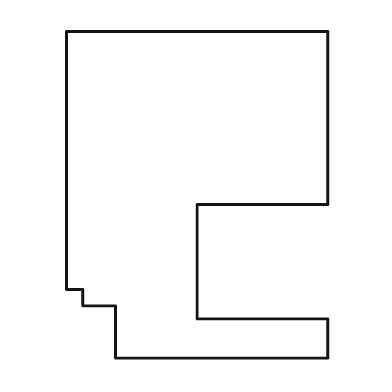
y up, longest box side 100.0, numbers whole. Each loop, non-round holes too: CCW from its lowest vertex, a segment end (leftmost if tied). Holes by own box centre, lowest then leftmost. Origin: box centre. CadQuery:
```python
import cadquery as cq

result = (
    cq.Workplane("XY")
    .moveTo(-25.0, -50.0)
    .lineTo(40.0, -50.0)
    .lineTo(40.0, -38.0)
    .lineTo(0.0, -38.0)
    .lineTo(0.0, -3.0)
    .lineTo(40.0, -3.0)
    .lineTo(40.0, 50.0)
    .lineTo(-40.0, 50.0)
    .lineTo(-40.0, -29.0)
    .lineTo(-35.0, -29.0)
    .lineTo(-35.0, -34.0)
    .lineTo(-25.0, -34.0)
    .close()
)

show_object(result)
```